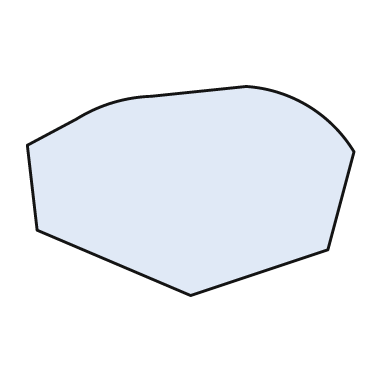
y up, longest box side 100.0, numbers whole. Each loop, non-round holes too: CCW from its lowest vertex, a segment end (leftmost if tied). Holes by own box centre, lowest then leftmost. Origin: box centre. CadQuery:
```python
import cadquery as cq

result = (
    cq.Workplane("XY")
    .moveTo(0.0, -32.0)
    .lineTo(42.0, -18.0)
    .lineTo(50.0, 12.0)
    .threePointArc((36.0, 26.0), (17.0, 32.0))
    .lineTo(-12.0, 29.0)
    .threePointArc((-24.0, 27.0), (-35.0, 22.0))
    .lineTo(-50.0, 14.0)
    .lineTo(-47.0, -12.0)
    .close()
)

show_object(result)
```